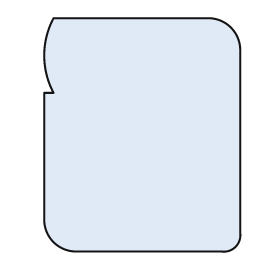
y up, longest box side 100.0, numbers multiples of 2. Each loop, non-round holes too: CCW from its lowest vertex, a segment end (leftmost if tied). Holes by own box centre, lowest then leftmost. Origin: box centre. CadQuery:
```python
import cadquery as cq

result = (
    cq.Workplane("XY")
    .moveTo(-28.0, -50.0)
    .lineTo(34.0, -50.0)
    .threePointArc((40.0, -48.0), (42.0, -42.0))
    .lineTo(42.0, 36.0)
    .threePointArc((38.0, 46.0), (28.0, 50.0))
    .lineTo(-38.0, 50.0)
    .threePointArc((-42.0, 34.0), (-38.0, 18.0))
    .lineTo(-42.0, 18.0)
    .lineTo(-42.0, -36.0)
    .threePointArc((-38.0, -46.0), (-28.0, -50.0))
    .close()
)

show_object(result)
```